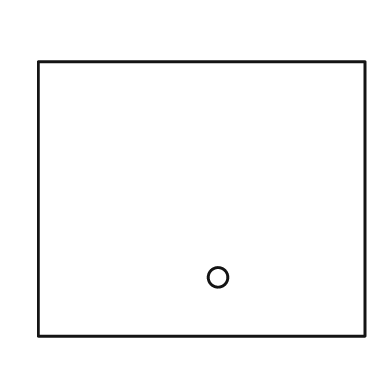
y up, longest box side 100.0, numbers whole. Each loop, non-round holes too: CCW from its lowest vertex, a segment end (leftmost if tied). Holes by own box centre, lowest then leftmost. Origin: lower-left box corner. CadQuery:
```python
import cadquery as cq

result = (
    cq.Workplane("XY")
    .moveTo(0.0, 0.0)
    .lineTo(100.0, 0.0)
    .lineTo(100.0, 84.0)
    .lineTo(0.0, 84.0)
    .close()
    .moveTo(55.0, 18.0)
    .circle(3.0)
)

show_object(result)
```